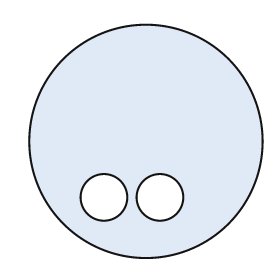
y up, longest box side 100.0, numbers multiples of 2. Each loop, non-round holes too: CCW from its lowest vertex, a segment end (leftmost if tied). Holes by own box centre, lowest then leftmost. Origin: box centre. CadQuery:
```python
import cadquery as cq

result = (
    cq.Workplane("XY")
    .moveTo(0.0, 0.0)
    .circle(50.0)
    .moveTo(-18.0, -24.0)
    .circle(10.0)
    .moveTo(6.0, -24.0)
    .circle(10.0)
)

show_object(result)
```